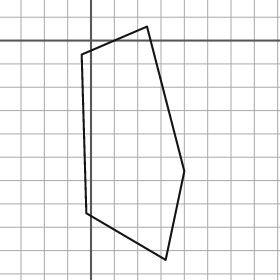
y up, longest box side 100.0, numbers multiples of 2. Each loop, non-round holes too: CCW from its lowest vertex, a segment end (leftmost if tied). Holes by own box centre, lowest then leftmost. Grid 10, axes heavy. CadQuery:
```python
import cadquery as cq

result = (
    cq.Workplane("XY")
    .moveTo(32.0, -94.0)
    .lineTo(40.0, -56.0)
    .lineTo(24.0, 6.0)
    .lineTo(-4.0, -6.0)
    .lineTo(-2.0, -74.0)
    .close()
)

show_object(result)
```